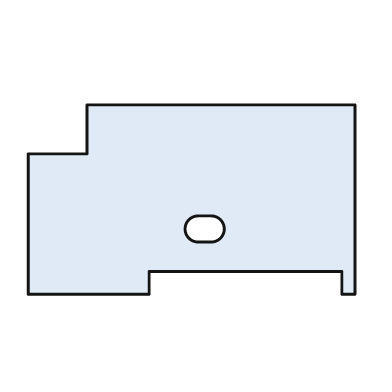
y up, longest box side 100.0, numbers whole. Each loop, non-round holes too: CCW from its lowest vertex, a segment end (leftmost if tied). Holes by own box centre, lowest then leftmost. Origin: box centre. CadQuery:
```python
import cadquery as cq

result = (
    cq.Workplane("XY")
    .moveTo(-50.0, -29.0)
    .lineTo(-13.0, -29.0)
    .lineTo(-13.0, -22.0)
    .lineTo(46.0, -22.0)
    .lineTo(46.0, -29.0)
    .lineTo(50.0, -29.0)
    .lineTo(50.0, 29.0)
    .lineTo(-32.0, 29.0)
    .lineTo(-32.0, 14.0)
    .lineTo(-50.0, 14.0)
    .close()
    .moveTo(2.0, -13.0)
    .lineTo(6.0, -13.0)
    .threePointArc((10.0, -9.0), (6.0, -5.0))
    .lineTo(2.0, -5.0)
    .threePointArc((-2.0, -9.0), (2.0, -13.0))
    .close()
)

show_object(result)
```